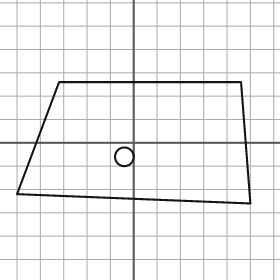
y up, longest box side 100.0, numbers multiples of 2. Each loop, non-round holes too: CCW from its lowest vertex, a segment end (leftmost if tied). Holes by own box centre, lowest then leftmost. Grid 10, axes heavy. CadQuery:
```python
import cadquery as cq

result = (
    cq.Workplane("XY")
    .moveTo(50.0, -26.0)
    .lineTo(46.0, 26.0)
    .lineTo(-32.0, 26.0)
    .lineTo(-50.0, -22.0)
    .close()
    .moveTo(-4.0, -6.0)
    .circle(4.0)
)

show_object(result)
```